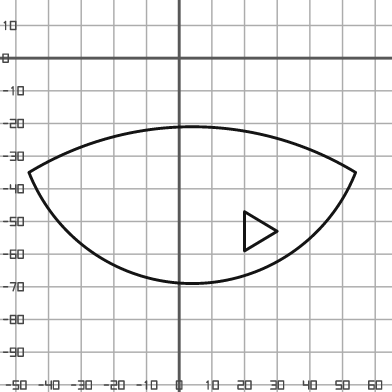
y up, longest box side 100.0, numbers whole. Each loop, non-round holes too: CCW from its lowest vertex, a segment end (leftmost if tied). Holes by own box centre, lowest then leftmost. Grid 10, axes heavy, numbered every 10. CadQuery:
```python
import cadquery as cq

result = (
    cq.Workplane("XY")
    .moveTo(-46.0, -35.0)
    .threePointArc((4.0, -69.0), (54.0, -35.0))
    .threePointArc((4.0, -21.0), (-46.0, -35.0))
    .close()
    .moveTo(20.0, -59.0)
    .lineTo(30.0, -53.0)
    .lineTo(20.0, -47.0)
    .close()
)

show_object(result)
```